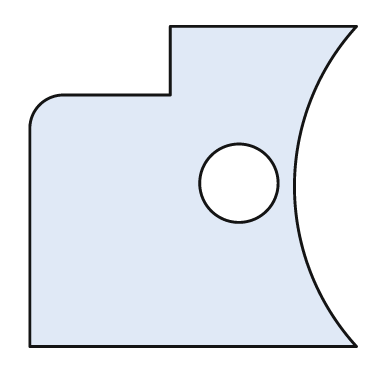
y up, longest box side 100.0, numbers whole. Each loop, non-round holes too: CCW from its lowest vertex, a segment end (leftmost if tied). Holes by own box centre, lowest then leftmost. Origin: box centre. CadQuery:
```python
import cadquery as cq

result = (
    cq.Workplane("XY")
    .moveTo(-50.0, -49.0)
    .lineTo(50.0, -49.0)
    .threePointArc((31.0, 0.0), (50.0, 49.0))
    .lineTo(-7.0, 49.0)
    .lineTo(-7.0, 28.0)
    .lineTo(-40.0, 28.0)
    .threePointArc((-47.0, 25.0), (-50.0, 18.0))
    .close()
    .moveTo(14.0, 1.0)
    .circle(12.0)
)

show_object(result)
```